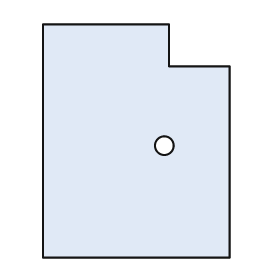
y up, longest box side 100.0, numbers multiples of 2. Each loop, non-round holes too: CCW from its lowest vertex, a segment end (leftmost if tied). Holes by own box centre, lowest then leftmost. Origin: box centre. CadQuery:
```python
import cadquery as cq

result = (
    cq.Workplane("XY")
    .moveTo(-40.0, -50.0)
    .lineTo(40.0, -50.0)
    .lineTo(40.0, 32.0)
    .lineTo(14.0, 32.0)
    .lineTo(14.0, 50.0)
    .lineTo(-40.0, 50.0)
    .close()
    .moveTo(12.0, -2.0)
    .circle(4.0)
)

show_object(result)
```